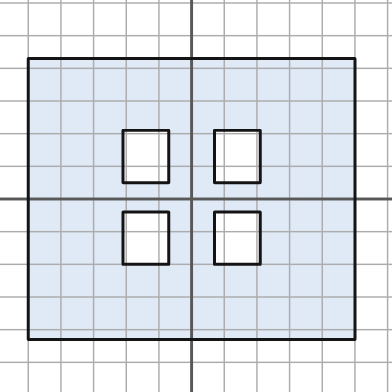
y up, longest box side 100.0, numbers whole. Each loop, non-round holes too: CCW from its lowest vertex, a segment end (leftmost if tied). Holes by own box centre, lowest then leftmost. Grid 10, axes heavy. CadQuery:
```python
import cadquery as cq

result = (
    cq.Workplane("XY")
    .moveTo(-50.0, -43.0)
    .lineTo(50.0, -43.0)
    .lineTo(50.0, 43.0)
    .lineTo(-50.0, 43.0)
    .close()
    .moveTo(-21.0, -20.0)
    .lineTo(-7.0, -20.0)
    .lineTo(-7.0, -4.0)
    .lineTo(-21.0, -4.0)
    .close()
    .moveTo(7.0, -20.0)
    .lineTo(21.0, -20.0)
    .lineTo(21.0, -4.0)
    .lineTo(7.0, -4.0)
    .close()
    .moveTo(-21.0, 5.0)
    .lineTo(-7.0, 5.0)
    .lineTo(-7.0, 21.0)
    .lineTo(-21.0, 21.0)
    .close()
    .moveTo(7.0, 5.0)
    .lineTo(21.0, 5.0)
    .lineTo(21.0, 21.0)
    .lineTo(7.0, 21.0)
    .close()
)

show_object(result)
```